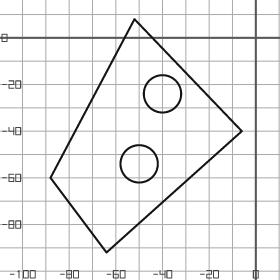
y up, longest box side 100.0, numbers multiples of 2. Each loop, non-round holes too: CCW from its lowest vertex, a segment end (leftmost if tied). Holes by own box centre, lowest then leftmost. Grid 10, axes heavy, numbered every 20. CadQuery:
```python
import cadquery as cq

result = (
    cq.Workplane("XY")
    .moveTo(-64.0, -92.0)
    .lineTo(-6.0, -40.0)
    .lineTo(-52.0, 8.0)
    .lineTo(-88.0, -60.0)
    .close()
    .moveTo(-50.0, -54.0)
    .circle(8.0)
    .moveTo(-40.0, -24.0)
    .circle(8.0)
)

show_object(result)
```